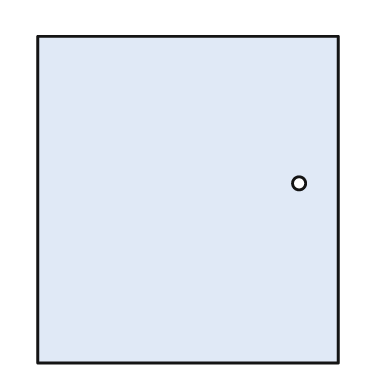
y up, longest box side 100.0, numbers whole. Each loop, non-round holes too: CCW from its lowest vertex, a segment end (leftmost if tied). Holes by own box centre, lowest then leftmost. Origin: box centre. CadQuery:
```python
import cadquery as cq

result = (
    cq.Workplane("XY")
    .moveTo(-46.0, -50.0)
    .lineTo(46.0, -50.0)
    .lineTo(46.0, 50.0)
    .lineTo(-46.0, 50.0)
    .close()
    .moveTo(34.0, 5.0)
    .circle(2.0)
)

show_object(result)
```